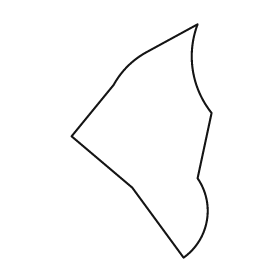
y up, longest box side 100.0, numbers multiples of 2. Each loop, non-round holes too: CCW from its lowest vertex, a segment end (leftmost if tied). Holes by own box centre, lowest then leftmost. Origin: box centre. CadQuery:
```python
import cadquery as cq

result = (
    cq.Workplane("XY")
    .moveTo(18.0, -50.0)
    .threePointArc((28.0, -34.0), (24.0, -16.0))
    .lineTo(30.0, 12.0)
    .threePointArc((22.0, 30.0), (24.0, 50.0))
    .lineTo(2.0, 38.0)
    .threePointArc((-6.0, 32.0), (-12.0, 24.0))
    .lineTo(-30.0, 2.0)
    .lineTo(-4.0, -20.0)
    .close()
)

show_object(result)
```